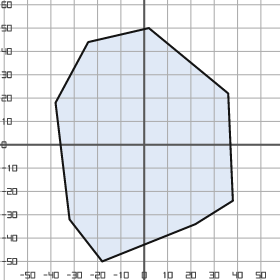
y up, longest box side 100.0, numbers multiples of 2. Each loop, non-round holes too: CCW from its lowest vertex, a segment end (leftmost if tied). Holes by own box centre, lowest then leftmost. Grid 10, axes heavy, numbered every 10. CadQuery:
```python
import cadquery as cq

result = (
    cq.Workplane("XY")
    .moveTo(-18.0, -50.0)
    .lineTo(22.0, -34.0)
    .lineTo(38.0, -24.0)
    .lineTo(36.0, 22.0)
    .lineTo(2.0, 50.0)
    .lineTo(-24.0, 44.0)
    .lineTo(-38.0, 18.0)
    .lineTo(-32.0, -32.0)
    .close()
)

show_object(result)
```